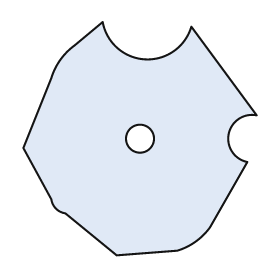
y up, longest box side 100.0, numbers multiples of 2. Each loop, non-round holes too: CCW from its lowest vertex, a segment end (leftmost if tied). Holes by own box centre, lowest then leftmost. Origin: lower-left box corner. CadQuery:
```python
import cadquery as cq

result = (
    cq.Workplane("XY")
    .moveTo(40.0, 0.0)
    .lineTo(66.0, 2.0)
    .threePointArc((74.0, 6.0), (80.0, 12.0))
    .lineTo(96.0, 40.0)
    .threePointArc((88.0, 52.0), (100.0, 60.0))
    .lineTo(72.0, 98.0)
    .threePointArc((52.0, 84.0), (34.0, 100.0))
    .lineTo(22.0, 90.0)
    .threePointArc((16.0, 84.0), (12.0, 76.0))
    .lineTo(0.0, 46.0)
    .lineTo(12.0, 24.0)
    .threePointArc((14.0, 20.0), (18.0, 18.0))
    .close()
    .moveTo(50.0, 50.0)
    .circle(6.0)
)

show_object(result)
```